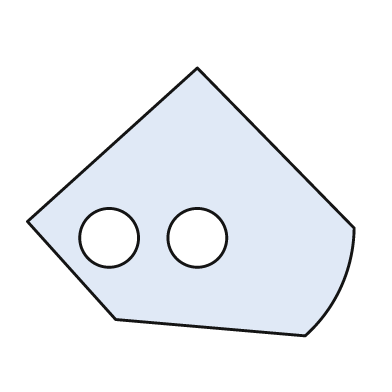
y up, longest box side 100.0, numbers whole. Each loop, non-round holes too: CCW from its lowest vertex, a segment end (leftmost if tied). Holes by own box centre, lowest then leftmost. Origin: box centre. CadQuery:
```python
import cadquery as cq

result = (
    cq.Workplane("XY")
    .moveTo(35.0, -41.0)
    .threePointArc((46.0, -26.0), (50.0, -8.0))
    .lineTo(2.0, 41.0)
    .lineTo(-50.0, -6.0)
    .lineTo(-23.0, -36.0)
    .close()
    .moveTo(-25.0, -11.0)
    .circle(9.0)
    .moveTo(2.0, -11.0)
    .circle(9.0)
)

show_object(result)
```